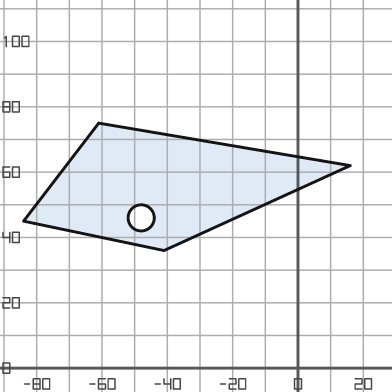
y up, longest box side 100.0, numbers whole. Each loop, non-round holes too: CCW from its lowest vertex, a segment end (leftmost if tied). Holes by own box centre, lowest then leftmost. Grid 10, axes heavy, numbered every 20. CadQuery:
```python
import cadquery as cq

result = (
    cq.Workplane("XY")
    .moveTo(-41.0, 36.0)
    .lineTo(16.0, 62.0)
    .lineTo(-61.0, 75.0)
    .lineTo(-84.0, 45.0)
    .close()
    .moveTo(-48.0, 46.0)
    .circle(4.0)
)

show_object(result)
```